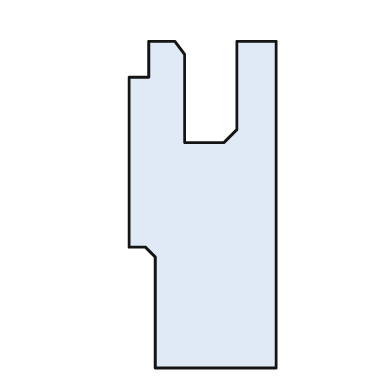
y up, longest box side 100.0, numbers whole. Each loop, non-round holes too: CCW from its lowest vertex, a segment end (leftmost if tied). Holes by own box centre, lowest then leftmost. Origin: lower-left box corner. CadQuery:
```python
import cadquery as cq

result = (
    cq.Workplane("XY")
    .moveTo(8.0, 0.0)
    .lineTo(45.0, 0.0)
    .lineTo(45.0, 100.0)
    .lineTo(33.0, 100.0)
    .lineTo(33.0, 73.0)
    .lineTo(29.0, 69.0)
    .lineTo(17.0, 69.0)
    .lineTo(17.0, 96.0)
    .lineTo(14.0, 100.0)
    .lineTo(6.0, 100.0)
    .lineTo(6.0, 89.0)
    .lineTo(0.0, 89.0)
    .lineTo(0.0, 37.0)
    .lineTo(5.0, 37.0)
    .lineTo(8.0, 34.0)
    .close()
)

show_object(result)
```